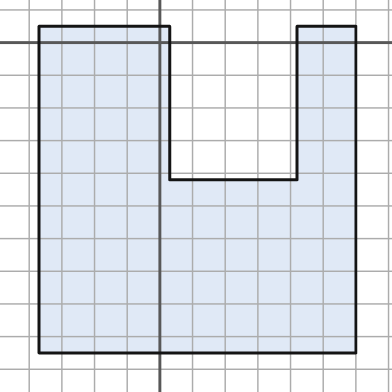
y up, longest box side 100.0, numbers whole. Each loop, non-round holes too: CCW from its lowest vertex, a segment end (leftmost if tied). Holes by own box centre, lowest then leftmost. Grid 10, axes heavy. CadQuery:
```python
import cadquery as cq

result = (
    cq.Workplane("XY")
    .moveTo(-37.0, -95.0)
    .lineTo(60.0, -95.0)
    .lineTo(60.0, 5.0)
    .lineTo(42.0, 5.0)
    .lineTo(42.0, -42.0)
    .lineTo(3.0, -42.0)
    .lineTo(3.0, 5.0)
    .lineTo(-37.0, 5.0)
    .close()
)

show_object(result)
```